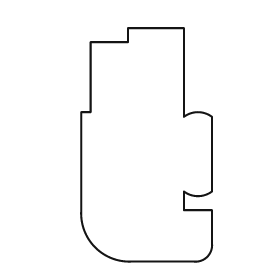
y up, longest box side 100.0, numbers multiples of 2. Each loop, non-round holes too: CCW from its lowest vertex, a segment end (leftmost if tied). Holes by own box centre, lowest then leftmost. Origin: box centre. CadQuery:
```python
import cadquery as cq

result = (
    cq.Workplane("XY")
    .moveTo(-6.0, -50.0)
    .lineTo(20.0, -50.0)
    .threePointArc((26.0, -48.0), (28.0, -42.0))
    .lineTo(28.0, -28.0)
    .lineTo(16.0, -28.0)
    .lineTo(16.0, -20.0)
    .threePointArc((22.0, -22.0), (28.0, -20.0))
    .lineTo(28.0, 12.0)
    .threePointArc((22.0, 14.0), (16.0, 12.0))
    .lineTo(16.0, 50.0)
    .lineTo(-8.0, 50.0)
    .lineTo(-8.0, 44.0)
    .lineTo(-24.0, 44.0)
    .lineTo(-24.0, 14.0)
    .lineTo(-28.0, 14.0)
    .lineTo(-28.0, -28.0)
    .threePointArc((-22.0, -44.0), (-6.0, -50.0))
    .close()
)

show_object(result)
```